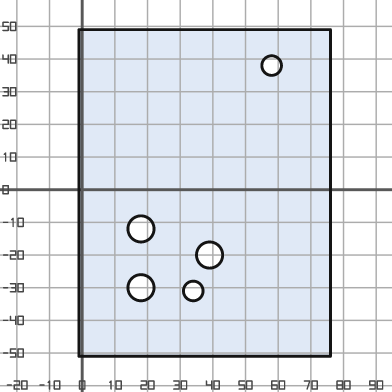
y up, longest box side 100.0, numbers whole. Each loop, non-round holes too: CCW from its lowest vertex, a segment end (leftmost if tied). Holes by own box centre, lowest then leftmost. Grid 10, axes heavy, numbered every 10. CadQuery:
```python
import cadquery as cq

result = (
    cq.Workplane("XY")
    .moveTo(-1.0, -51.0)
    .lineTo(76.0, -51.0)
    .lineTo(76.0, 49.0)
    .lineTo(-1.0, 49.0)
    .close()
    .moveTo(34.0, -31.0)
    .circle(3.0)
    .moveTo(18.0, -30.0)
    .circle(4.0)
    .moveTo(39.0, -20.0)
    .circle(4.0)
    .moveTo(18.0, -12.0)
    .circle(4.0)
    .moveTo(58.0, 38.0)
    .circle(3.0)
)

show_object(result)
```